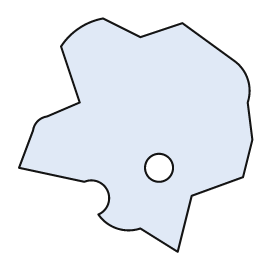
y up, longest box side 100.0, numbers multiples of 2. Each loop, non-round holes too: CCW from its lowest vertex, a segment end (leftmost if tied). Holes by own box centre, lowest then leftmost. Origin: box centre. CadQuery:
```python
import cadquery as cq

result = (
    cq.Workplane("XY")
    .moveTo(18.0, -50.0)
    .lineTo(24.0, -26.0)
    .lineTo(46.0, -18.0)
    .lineTo(50.0, -2.0)
    .lineTo(48.0, 14.0)
    .threePointArc((48.0, 24.0), (42.0, 32.0))
    .lineTo(20.0, 48.0)
    .lineTo(2.0, 42.0)
    .lineTo(-14.0, 50.0)
    .threePointArc((-24.0, 46.0), (-32.0, 38.0))
    .lineTo(-24.0, 14.0)
    .lineTo(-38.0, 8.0)
    .threePointArc((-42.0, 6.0), (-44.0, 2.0))
    .lineTo(-50.0, -14.0)
    .lineTo(-22.0, -20.0)
    .threePointArc((-12.0, -24.0), (-16.0, -34.0))
    .threePointArc((-8.0, -40.0), (2.0, -40.0))
    .close()
    .moveTo(10.0, -14.0)
    .circle(6.0)
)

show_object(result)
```